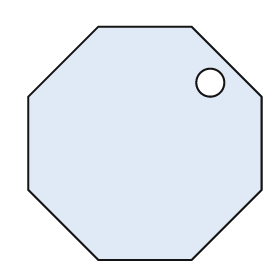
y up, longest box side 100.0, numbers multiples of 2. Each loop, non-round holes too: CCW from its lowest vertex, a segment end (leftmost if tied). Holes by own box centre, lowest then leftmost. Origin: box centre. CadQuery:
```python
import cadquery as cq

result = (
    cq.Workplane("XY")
    .moveTo(-20.0, -50.0)
    .lineTo(20.0, -50.0)
    .lineTo(50.0, -20.0)
    .lineTo(50.0, 20.0)
    .lineTo(20.0, 50.0)
    .lineTo(-20.0, 50.0)
    .lineTo(-50.0, 20.0)
    .lineTo(-50.0, -20.0)
    .close()
    .moveTo(28.0, 26.0)
    .circle(6.0)
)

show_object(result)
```